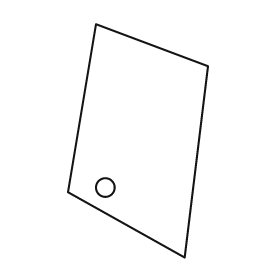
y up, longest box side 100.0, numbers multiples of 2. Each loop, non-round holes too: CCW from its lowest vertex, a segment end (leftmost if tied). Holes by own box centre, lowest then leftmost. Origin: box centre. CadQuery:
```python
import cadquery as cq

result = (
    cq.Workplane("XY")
    .moveTo(20.0, -50.0)
    .lineTo(30.0, 32.0)
    .lineTo(-18.0, 50.0)
    .lineTo(-30.0, -22.0)
    .close()
    .moveTo(-14.0, -20.0)
    .circle(4.0)
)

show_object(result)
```